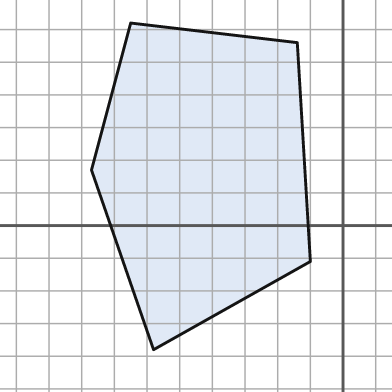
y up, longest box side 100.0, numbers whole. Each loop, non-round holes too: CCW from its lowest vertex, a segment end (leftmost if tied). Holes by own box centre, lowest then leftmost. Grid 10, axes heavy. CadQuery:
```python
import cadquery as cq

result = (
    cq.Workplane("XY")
    .moveTo(-58.0, -38.0)
    .lineTo(-10.0, -11.0)
    .lineTo(-14.0, 56.0)
    .lineTo(-65.0, 62.0)
    .lineTo(-77.0, 17.0)
    .close()
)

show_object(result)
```